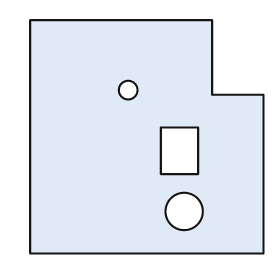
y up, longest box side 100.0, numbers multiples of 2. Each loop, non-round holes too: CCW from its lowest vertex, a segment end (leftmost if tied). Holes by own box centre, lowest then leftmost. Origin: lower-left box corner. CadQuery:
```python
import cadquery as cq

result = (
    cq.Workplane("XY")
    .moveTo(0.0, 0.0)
    .lineTo(100.0, 0.0)
    .lineTo(100.0, 68.0)
    .lineTo(78.0, 68.0)
    .lineTo(78.0, 100.0)
    .lineTo(0.0, 100.0)
    .close()
    .moveTo(66.0, 18.0)
    .circle(8.0)
    .moveTo(56.0, 34.0)
    .lineTo(72.0, 34.0)
    .lineTo(72.0, 54.0)
    .lineTo(56.0, 54.0)
    .close()
    .moveTo(42.0, 70.0)
    .circle(4.0)
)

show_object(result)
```